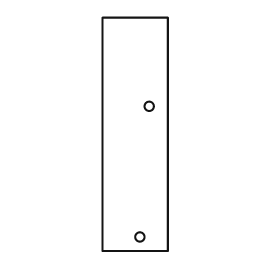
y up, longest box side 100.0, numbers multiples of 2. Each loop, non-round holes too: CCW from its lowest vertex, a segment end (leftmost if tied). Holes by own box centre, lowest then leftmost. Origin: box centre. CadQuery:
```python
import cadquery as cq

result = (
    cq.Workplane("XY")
    .moveTo(-14.0, -50.0)
    .lineTo(14.0, -50.0)
    .lineTo(14.0, 50.0)
    .lineTo(-14.0, 50.0)
    .close()
    .moveTo(2.0, -44.0)
    .circle(2.0)
    .moveTo(6.0, 12.0)
    .circle(2.0)
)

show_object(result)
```